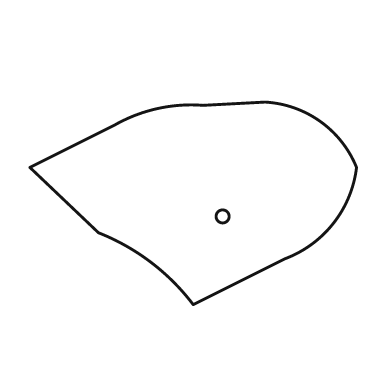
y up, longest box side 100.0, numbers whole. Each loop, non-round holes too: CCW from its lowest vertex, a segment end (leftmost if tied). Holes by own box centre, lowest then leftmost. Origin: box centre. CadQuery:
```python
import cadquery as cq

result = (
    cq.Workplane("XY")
    .moveTo(0.0, -31.0)
    .lineTo(28.0, -17.0)
    .threePointArc((43.0, -6.0), (50.0, 11.0))
    .threePointArc((39.0, 25.0), (22.0, 31.0))
    .lineTo(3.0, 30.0)
    .threePointArc((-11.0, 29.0), (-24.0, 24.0))
    .lineTo(-50.0, 11.0)
    .lineTo(-29.0, -9.0)
    .threePointArc((-13.0, -18.0), (0.0, -31.0))
    .close()
    .moveTo(9.0, -4.0)
    .circle(2.0)
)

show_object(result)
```